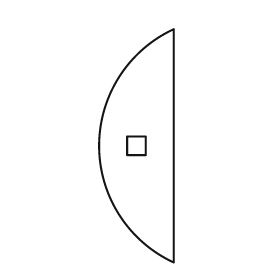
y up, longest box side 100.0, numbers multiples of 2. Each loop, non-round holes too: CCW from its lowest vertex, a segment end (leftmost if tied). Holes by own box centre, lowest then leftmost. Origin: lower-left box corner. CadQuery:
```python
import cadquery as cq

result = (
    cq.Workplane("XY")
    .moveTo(32.0, 0.0)
    .lineTo(32.0, 100.0)
    .threePointArc((0.0, 50.0), (32.0, 0.0))
    .close()
    .moveTo(12.0, 46.0)
    .lineTo(20.0, 46.0)
    .lineTo(20.0, 54.0)
    .lineTo(12.0, 54.0)
    .close()
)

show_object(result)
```